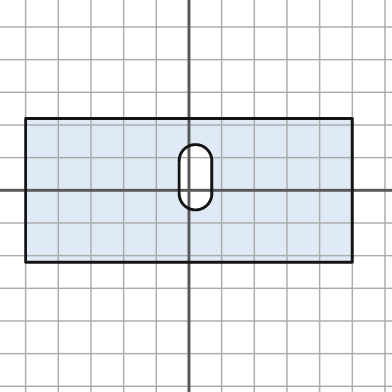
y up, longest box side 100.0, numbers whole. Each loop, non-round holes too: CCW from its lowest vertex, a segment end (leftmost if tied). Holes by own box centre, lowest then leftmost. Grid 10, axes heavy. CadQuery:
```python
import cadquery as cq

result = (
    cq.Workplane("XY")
    .moveTo(-50.0, -22.0)
    .lineTo(50.0, -22.0)
    .lineTo(50.0, 22.0)
    .lineTo(-50.0, 22.0)
    .close()
    .moveTo(-3.0, -1.0)
    .threePointArc((2.0, -6.0), (7.0, -1.0))
    .lineTo(7.0, 9.0)
    .threePointArc((2.0, 14.0), (-3.0, 9.0))
    .close()
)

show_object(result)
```